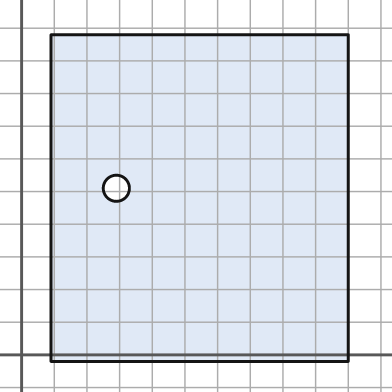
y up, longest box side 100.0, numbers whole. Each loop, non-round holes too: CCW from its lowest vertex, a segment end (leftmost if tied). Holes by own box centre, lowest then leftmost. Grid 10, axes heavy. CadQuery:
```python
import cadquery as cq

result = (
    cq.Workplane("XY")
    .moveTo(9.0, -2.0)
    .lineTo(100.0, -2.0)
    .lineTo(100.0, 98.0)
    .lineTo(9.0, 98.0)
    .close()
    .moveTo(29.0, 51.0)
    .circle(4.0)
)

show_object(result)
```